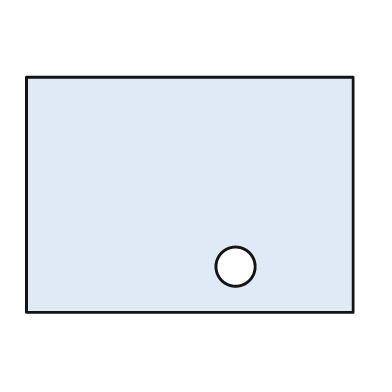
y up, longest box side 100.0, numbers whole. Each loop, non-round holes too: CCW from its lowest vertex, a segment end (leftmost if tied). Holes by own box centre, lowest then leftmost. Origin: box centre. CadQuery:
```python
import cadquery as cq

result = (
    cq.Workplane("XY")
    .moveTo(-50.0, -36.0)
    .lineTo(50.0, -36.0)
    .lineTo(50.0, 36.0)
    .lineTo(-50.0, 36.0)
    .close()
    .moveTo(14.0, -22.0)
    .circle(6.0)
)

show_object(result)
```